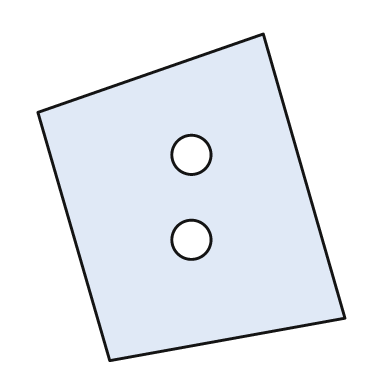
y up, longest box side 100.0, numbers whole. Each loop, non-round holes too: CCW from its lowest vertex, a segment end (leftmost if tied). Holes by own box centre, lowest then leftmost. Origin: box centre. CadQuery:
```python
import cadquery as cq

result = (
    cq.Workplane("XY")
    .moveTo(-25.0, -50.0)
    .lineTo(47.0, -37.0)
    .lineTo(22.0, 50.0)
    .lineTo(-47.0, 26.0)
    .close()
    .moveTo(0.0, -13.0)
    .circle(6.0)
    .moveTo(0.0, 13.0)
    .circle(6.0)
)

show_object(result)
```